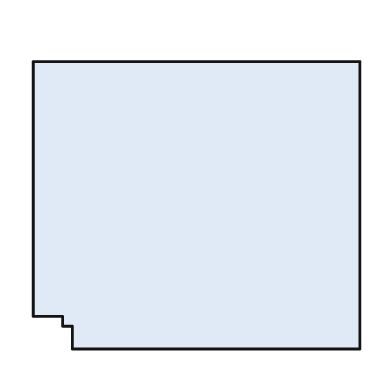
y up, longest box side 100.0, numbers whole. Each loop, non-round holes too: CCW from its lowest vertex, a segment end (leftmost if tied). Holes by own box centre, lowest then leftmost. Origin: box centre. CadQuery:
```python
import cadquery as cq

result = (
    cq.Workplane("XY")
    .moveTo(-38.0, -44.0)
    .lineTo(50.0, -44.0)
    .lineTo(50.0, 44.0)
    .lineTo(-50.0, 44.0)
    .lineTo(-50.0, -34.0)
    .lineTo(-41.0, -34.0)
    .lineTo(-41.0, -37.0)
    .lineTo(-38.0, -37.0)
    .close()
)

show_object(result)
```